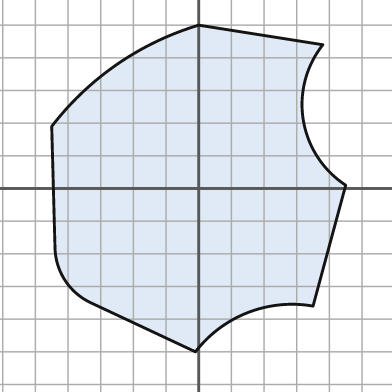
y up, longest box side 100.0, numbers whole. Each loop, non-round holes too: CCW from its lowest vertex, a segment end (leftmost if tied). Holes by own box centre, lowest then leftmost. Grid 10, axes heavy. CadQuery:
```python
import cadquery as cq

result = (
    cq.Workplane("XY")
    .moveTo(-1.0, -50.0)
    .threePointArc((15.0, -38.0), (35.0, -36.0))
    .lineTo(45.0, 1.0)
    .threePointArc((32.0, 21.0), (38.0, 44.0))
    .lineTo(0.0, 50.0)
    .threePointArc((-25.0, 38.0), (-45.0, 19.0))
    .lineTo(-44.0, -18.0)
    .threePointArc((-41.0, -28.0), (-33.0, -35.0))
    .close()
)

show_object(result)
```